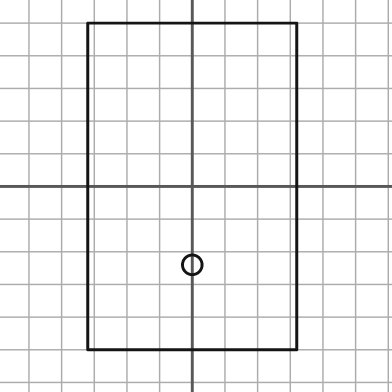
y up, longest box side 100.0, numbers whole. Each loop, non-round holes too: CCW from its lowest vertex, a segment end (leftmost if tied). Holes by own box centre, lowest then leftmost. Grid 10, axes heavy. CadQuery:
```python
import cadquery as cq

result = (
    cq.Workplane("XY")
    .moveTo(-32.0, -50.0)
    .lineTo(32.0, -50.0)
    .lineTo(32.0, 50.0)
    .lineTo(-32.0, 50.0)
    .close()
    .moveTo(0.0, -24.0)
    .circle(3.0)
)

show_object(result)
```